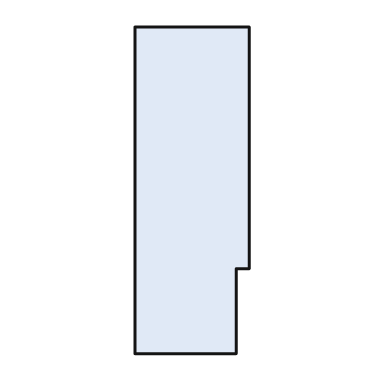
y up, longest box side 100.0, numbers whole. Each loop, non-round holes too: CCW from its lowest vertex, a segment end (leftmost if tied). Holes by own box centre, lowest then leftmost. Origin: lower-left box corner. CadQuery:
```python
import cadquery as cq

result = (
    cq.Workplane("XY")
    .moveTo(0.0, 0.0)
    .lineTo(31.0, 0.0)
    .lineTo(31.0, 26.0)
    .lineTo(35.0, 26.0)
    .lineTo(35.0, 100.0)
    .lineTo(0.0, 100.0)
    .close()
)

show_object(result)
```